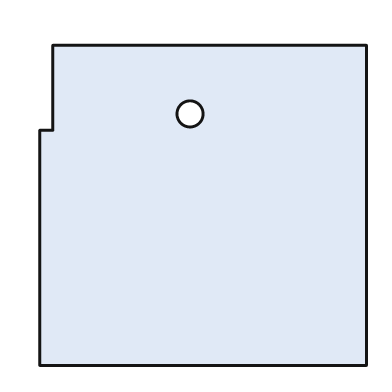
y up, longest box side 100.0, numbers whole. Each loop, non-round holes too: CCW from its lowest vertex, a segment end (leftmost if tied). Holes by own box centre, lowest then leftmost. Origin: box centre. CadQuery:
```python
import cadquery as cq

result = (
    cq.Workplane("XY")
    .moveTo(-50.0, -49.0)
    .lineTo(50.0, -49.0)
    .lineTo(50.0, 49.0)
    .lineTo(-46.0, 49.0)
    .lineTo(-46.0, 23.0)
    .lineTo(-50.0, 23.0)
    .close()
    .moveTo(-4.0, 28.0)
    .circle(4.0)
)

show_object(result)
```